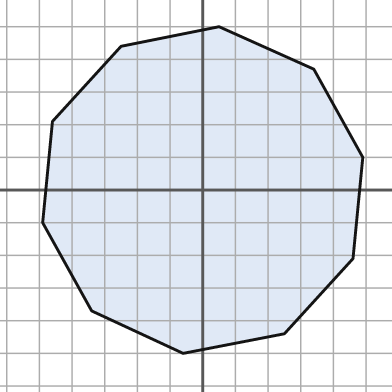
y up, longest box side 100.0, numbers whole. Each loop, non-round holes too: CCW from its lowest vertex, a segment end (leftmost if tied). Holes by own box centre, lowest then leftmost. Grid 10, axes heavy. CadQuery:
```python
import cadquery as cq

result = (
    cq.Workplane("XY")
    .moveTo(-6.0, -50.0)
    .lineTo(25.0, -44.0)
    .lineTo(46.0, -21.0)
    .lineTo(49.0, 10.0)
    .lineTo(34.0, 37.0)
    .lineTo(5.0, 50.0)
    .lineTo(-25.0, 44.0)
    .lineTo(-46.0, 21.0)
    .lineTo(-49.0, -10.0)
    .lineTo(-34.0, -37.0)
    .close()
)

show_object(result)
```